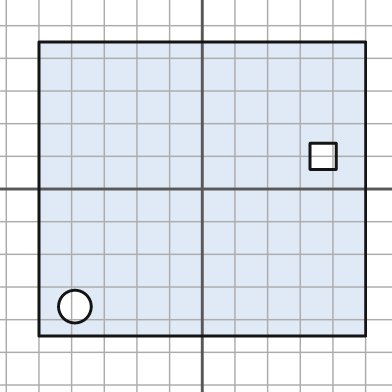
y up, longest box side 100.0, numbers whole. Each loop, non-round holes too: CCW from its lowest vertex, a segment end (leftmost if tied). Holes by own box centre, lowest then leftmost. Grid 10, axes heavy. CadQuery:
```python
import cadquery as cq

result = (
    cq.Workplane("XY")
    .moveTo(-50.0, -45.0)
    .lineTo(50.0, -45.0)
    .lineTo(50.0, 45.0)
    .lineTo(-50.0, 45.0)
    .close()
    .moveTo(-39.0, -36.0)
    .circle(5.0)
    .moveTo(33.0, 6.0)
    .lineTo(41.0, 6.0)
    .lineTo(41.0, 14.0)
    .lineTo(33.0, 14.0)
    .close()
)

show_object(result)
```